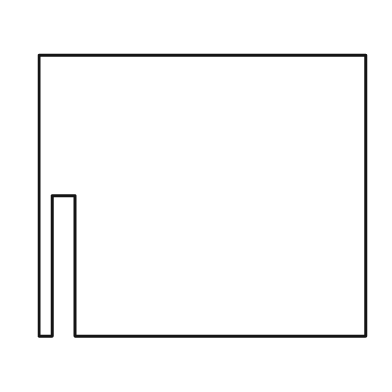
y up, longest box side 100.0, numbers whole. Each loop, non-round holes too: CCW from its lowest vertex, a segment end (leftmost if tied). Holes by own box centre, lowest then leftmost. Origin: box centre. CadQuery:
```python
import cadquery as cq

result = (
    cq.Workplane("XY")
    .moveTo(-50.0, -43.0)
    .lineTo(-46.0, -43.0)
    .lineTo(-46.0, 0.0)
    .lineTo(-39.0, 0.0)
    .lineTo(-39.0, -43.0)
    .lineTo(50.0, -43.0)
    .lineTo(50.0, 43.0)
    .lineTo(-50.0, 43.0)
    .close()
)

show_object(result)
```